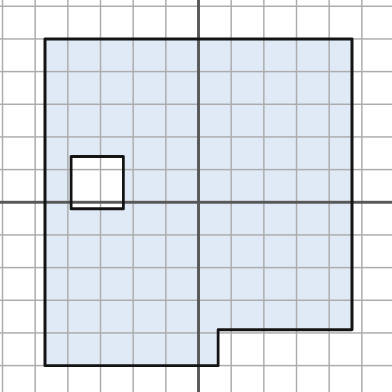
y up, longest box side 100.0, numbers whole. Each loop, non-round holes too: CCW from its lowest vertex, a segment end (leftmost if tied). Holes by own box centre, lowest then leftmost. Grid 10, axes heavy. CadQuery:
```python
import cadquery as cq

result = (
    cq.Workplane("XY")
    .moveTo(-47.0, -50.0)
    .lineTo(6.0, -50.0)
    .lineTo(6.0, -39.0)
    .lineTo(47.0, -39.0)
    .lineTo(47.0, 50.0)
    .lineTo(-47.0, 50.0)
    .close()
    .moveTo(-39.0, -2.0)
    .lineTo(-23.0, -2.0)
    .lineTo(-23.0, 14.0)
    .lineTo(-39.0, 14.0)
    .close()
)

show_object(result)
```